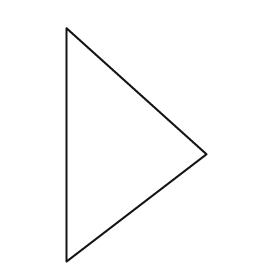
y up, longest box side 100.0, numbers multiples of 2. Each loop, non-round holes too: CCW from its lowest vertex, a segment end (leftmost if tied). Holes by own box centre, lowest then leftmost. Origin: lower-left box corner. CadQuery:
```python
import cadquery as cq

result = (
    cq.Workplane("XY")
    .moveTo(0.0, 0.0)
    .lineTo(60.0, 46.0)
    .lineTo(0.0, 100.0)
    .close()
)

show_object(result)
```